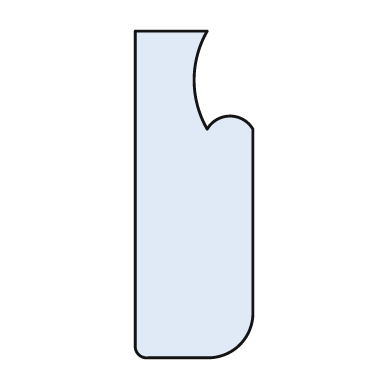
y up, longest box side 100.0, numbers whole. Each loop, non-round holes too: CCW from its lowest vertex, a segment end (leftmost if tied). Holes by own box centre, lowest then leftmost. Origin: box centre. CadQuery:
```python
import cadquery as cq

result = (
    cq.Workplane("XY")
    .moveTo(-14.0, -50.0)
    .lineTo(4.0, -50.0)
    .threePointArc((14.0, -46.0), (18.0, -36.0))
    .lineTo(18.0, 20.0)
    .threePointArc((11.0, 24.0), (4.0, 20.0))
    .threePointArc((0.0, 35.0), (4.0, 50.0))
    .lineTo(-18.0, 50.0)
    .lineTo(-18.0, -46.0)
    .threePointArc((-17.0, -49.0), (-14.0, -50.0))
    .close()
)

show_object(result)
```